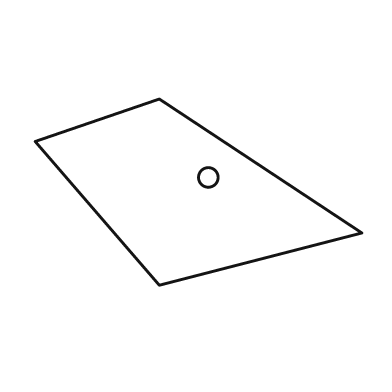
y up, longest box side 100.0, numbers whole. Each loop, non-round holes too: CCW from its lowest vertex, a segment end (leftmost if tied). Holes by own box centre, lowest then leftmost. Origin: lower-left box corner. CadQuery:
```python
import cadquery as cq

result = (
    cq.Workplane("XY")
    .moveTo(38.0, 0.0)
    .lineTo(100.0, 16.0)
    .lineTo(38.0, 57.0)
    .lineTo(0.0, 44.0)
    .close()
    .moveTo(53.0, 33.0)
    .circle(3.0)
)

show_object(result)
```